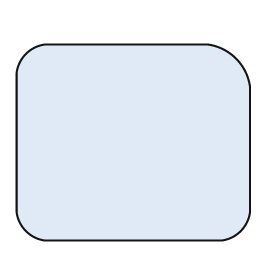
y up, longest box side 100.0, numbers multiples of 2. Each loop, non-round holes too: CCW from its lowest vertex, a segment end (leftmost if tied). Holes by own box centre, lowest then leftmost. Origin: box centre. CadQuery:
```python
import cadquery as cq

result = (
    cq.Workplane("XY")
    .moveTo(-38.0, -42.0)
    .lineTo(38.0, -42.0)
    .threePointArc((46.0, -38.0), (50.0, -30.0))
    .lineTo(50.0, 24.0)
    .threePointArc((44.0, 36.0), (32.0, 42.0))
    .lineTo(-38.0, 42.0)
    .threePointArc((-46.0, 38.0), (-50.0, 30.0))
    .lineTo(-50.0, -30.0)
    .threePointArc((-46.0, -38.0), (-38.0, -42.0))
    .close()
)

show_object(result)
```